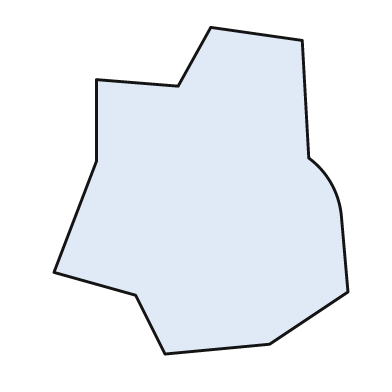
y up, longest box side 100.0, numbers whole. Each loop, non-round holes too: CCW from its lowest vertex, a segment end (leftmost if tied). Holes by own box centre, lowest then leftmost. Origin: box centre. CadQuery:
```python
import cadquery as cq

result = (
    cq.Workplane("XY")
    .moveTo(-11.0, -50.0)
    .lineTo(21.0, -47.0)
    .lineTo(45.0, -31.0)
    .lineTo(43.0, -8.0)
    .threePointArc((40.0, 2.0), (33.0, 10.0))
    .lineTo(31.0, 46.0)
    .lineTo(3.0, 50.0)
    .lineTo(-7.0, 32.0)
    .lineTo(-32.0, 34.0)
    .lineTo(-32.0, 9.0)
    .lineTo(-45.0, -25.0)
    .lineTo(-20.0, -32.0)
    .close()
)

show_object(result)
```